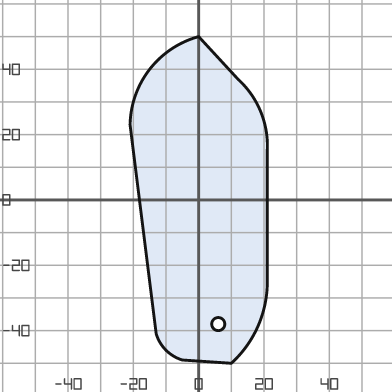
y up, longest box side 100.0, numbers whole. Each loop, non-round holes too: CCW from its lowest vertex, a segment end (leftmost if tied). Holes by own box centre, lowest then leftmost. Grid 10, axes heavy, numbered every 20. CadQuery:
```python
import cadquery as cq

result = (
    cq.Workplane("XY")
    .moveTo(10.0, -50.0)
    .threePointArc((18.0, -39.0), (21.0, -26.0))
    .lineTo(21.0, 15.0)
    .threePointArc((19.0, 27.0), (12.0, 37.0))
    .lineTo(0.0, 50.0)
    .threePointArc((-15.0, 40.0), (-21.0, 23.0))
    .lineTo(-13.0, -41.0)
    .threePointArc((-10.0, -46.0), (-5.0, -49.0))
    .close()
    .moveTo(6.0, -38.0)
    .circle(2.0)
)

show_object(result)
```